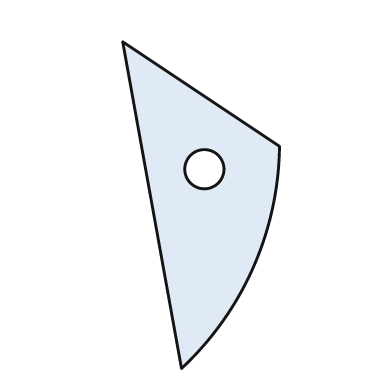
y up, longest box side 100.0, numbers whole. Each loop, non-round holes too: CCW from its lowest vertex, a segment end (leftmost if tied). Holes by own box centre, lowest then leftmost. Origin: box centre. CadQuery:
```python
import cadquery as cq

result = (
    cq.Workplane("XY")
    .moveTo(-6.0, -50.0)
    .threePointArc((16.0, -19.0), (24.0, 18.0))
    .lineTo(-24.0, 50.0)
    .close()
    .moveTo(1.0, 11.0)
    .circle(6.0)
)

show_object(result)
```